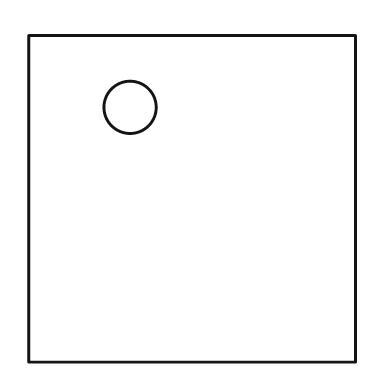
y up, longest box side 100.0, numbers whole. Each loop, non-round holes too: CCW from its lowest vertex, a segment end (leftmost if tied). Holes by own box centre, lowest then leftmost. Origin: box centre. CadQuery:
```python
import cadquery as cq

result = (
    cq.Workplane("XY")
    .moveTo(-50.0, -50.0)
    .lineTo(50.0, -50.0)
    .lineTo(50.0, 50.0)
    .lineTo(-50.0, 50.0)
    .close()
    .moveTo(-19.0, 28.0)
    .circle(8.0)
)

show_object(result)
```